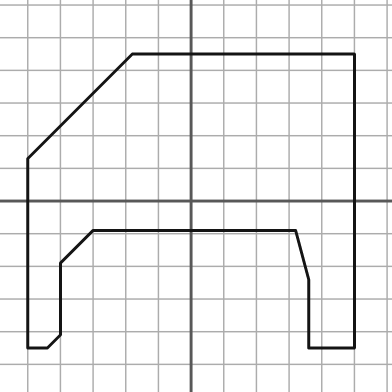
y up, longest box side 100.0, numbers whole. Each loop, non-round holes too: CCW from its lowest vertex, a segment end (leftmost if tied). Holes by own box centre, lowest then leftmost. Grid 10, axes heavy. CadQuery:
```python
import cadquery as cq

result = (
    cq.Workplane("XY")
    .moveTo(-50.0, -45.0)
    .lineTo(-44.0, -45.0)
    .lineTo(-40.0, -41.0)
    .lineTo(-40.0, -19.0)
    .lineTo(-30.0, -9.0)
    .lineTo(32.0, -9.0)
    .lineTo(36.0, -24.0)
    .lineTo(36.0, -45.0)
    .lineTo(50.0, -45.0)
    .lineTo(50.0, 45.0)
    .lineTo(-18.0, 45.0)
    .lineTo(-50.0, 13.0)
    .close()
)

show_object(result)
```